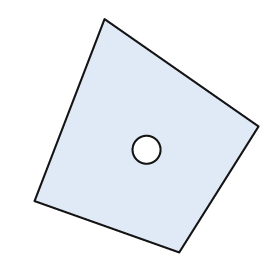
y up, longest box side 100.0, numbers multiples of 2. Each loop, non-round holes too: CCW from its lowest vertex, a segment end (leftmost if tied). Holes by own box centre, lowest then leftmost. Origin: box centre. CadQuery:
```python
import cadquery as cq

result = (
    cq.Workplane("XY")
    .moveTo(14.0, -50.0)
    .lineTo(48.0, 4.0)
    .lineTo(-18.0, 50.0)
    .lineTo(-48.0, -28.0)
    .close()
    .moveTo(0.0, -6.0)
    .circle(6.0)
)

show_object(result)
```